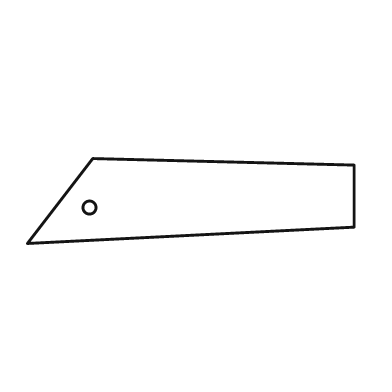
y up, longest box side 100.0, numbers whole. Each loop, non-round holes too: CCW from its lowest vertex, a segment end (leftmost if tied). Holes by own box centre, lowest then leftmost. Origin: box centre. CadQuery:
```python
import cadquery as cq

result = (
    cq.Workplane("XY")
    .moveTo(-50.0, -13.0)
    .lineTo(50.0, -8.0)
    .lineTo(50.0, 11.0)
    .lineTo(-30.0, 13.0)
    .close()
    .moveTo(-31.0, -2.0)
    .circle(2.0)
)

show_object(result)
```